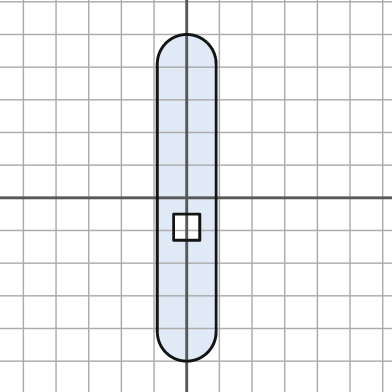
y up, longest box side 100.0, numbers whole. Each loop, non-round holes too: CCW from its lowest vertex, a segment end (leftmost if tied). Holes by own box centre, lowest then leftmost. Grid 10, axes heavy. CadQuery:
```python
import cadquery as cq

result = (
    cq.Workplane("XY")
    .moveTo(-9.0, -41.0)
    .threePointArc((0.0, -50.0), (9.0, -41.0))
    .lineTo(9.0, 41.0)
    .threePointArc((0.0, 50.0), (-9.0, 41.0))
    .close()
    .moveTo(-4.0, -13.0)
    .lineTo(4.0, -13.0)
    .lineTo(4.0, -5.0)
    .lineTo(-4.0, -5.0)
    .close()
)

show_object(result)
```